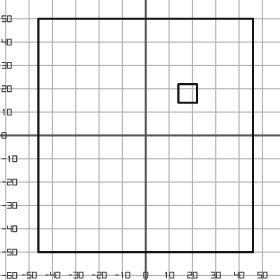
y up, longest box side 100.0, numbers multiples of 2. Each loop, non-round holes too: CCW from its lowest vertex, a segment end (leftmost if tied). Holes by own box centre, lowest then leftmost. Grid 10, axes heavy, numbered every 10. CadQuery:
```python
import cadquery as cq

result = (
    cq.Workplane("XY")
    .moveTo(-46.0, -50.0)
    .lineTo(46.0, -50.0)
    .lineTo(46.0, 50.0)
    .lineTo(-46.0, 50.0)
    .close()
    .moveTo(14.0, 14.0)
    .lineTo(22.0, 14.0)
    .lineTo(22.0, 22.0)
    .lineTo(14.0, 22.0)
    .close()
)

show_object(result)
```